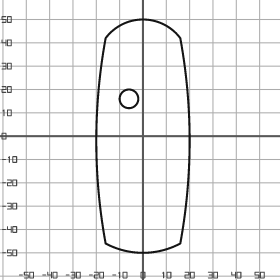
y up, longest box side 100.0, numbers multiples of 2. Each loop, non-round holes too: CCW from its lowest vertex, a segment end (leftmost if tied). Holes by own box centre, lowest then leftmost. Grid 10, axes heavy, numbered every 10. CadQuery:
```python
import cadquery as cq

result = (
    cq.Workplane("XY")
    .moveTo(-16.0, -46.0)
    .threePointArc((0.0, -50.0), (16.0, -46.0))
    .threePointArc((20.0, -2.0), (16.0, 42.0))
    .threePointArc((0.0, 50.0), (-16.0, 42.0))
    .threePointArc((-20.0, -2.0), (-16.0, -46.0))
    .close()
    .moveTo(-6.0, 16.0)
    .circle(4.0)
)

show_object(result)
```